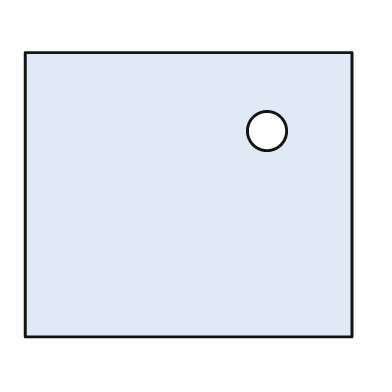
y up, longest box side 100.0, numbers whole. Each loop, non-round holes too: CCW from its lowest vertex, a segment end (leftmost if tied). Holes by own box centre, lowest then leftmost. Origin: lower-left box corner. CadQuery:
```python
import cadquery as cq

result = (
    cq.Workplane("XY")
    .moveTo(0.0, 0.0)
    .lineTo(100.0, 0.0)
    .lineTo(100.0, 87.0)
    .lineTo(0.0, 87.0)
    .close()
    .moveTo(74.0, 63.0)
    .circle(6.0)
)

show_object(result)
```